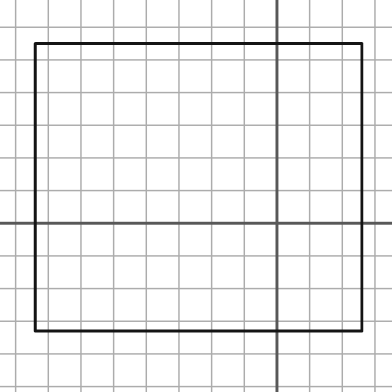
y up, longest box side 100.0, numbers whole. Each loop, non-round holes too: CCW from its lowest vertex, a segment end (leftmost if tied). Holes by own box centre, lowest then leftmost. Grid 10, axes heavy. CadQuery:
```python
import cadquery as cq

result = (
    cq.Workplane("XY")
    .moveTo(-74.0, -33.0)
    .lineTo(26.0, -33.0)
    .lineTo(26.0, 55.0)
    .lineTo(-74.0, 55.0)
    .close()
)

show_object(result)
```